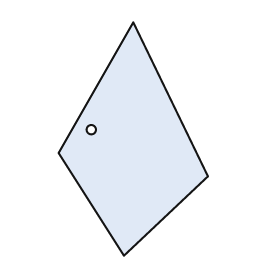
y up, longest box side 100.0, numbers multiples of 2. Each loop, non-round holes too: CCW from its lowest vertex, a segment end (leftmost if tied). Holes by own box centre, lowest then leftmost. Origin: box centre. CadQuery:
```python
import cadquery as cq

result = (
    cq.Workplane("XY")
    .moveTo(-4.0, -50.0)
    .lineTo(32.0, -16.0)
    .lineTo(0.0, 50.0)
    .lineTo(-32.0, -6.0)
    .close()
    .moveTo(-18.0, 4.0)
    .circle(2.0)
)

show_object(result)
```